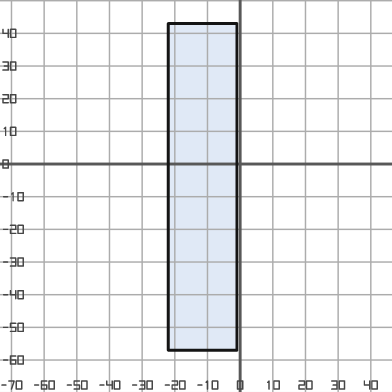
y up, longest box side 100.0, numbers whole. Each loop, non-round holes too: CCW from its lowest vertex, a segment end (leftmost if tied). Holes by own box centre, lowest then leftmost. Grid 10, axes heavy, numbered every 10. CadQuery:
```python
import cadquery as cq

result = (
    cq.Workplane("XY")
    .moveTo(-22.0, -57.0)
    .lineTo(-1.0, -57.0)
    .lineTo(-1.0, 43.0)
    .lineTo(-22.0, 43.0)
    .close()
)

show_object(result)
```